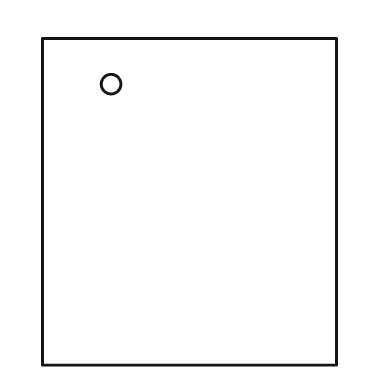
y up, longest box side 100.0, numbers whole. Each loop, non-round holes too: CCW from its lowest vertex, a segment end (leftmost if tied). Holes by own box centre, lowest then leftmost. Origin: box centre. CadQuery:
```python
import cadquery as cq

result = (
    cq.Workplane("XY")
    .moveTo(-45.0, -50.0)
    .lineTo(45.0, -50.0)
    .lineTo(45.0, 50.0)
    .lineTo(-45.0, 50.0)
    .close()
    .moveTo(-24.0, 36.0)
    .circle(3.0)
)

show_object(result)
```